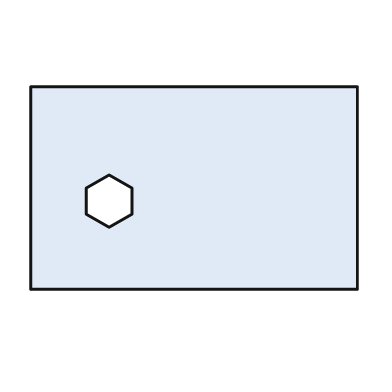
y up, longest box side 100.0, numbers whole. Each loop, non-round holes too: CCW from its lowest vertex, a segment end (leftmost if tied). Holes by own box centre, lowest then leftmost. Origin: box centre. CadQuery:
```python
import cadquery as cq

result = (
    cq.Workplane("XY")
    .moveTo(-50.0, -31.0)
    .lineTo(50.0, -31.0)
    .lineTo(50.0, 31.0)
    .lineTo(-50.0, 31.0)
    .close()
    .moveTo(-26.0, -12.0)
    .lineTo(-19.0, -8.0)
    .lineTo(-19.0, 0.0)
    .lineTo(-26.0, 4.0)
    .lineTo(-33.0, 0.0)
    .lineTo(-33.0, -8.0)
    .close()
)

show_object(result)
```